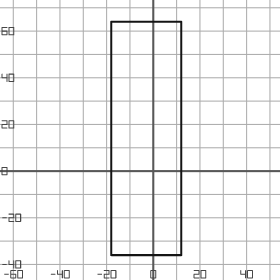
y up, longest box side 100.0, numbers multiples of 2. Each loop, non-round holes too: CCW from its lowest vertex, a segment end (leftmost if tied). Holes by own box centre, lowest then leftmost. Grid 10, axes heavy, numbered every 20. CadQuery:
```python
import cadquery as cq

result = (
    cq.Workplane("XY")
    .moveTo(-18.0, -36.0)
    .lineTo(12.0, -36.0)
    .lineTo(12.0, 64.0)
    .lineTo(-18.0, 64.0)
    .close()
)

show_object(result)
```